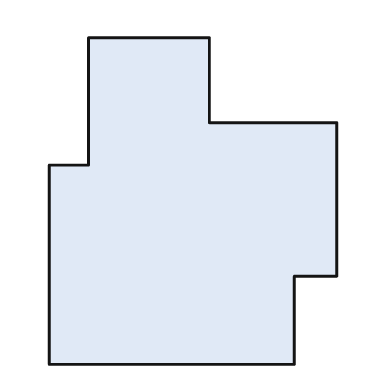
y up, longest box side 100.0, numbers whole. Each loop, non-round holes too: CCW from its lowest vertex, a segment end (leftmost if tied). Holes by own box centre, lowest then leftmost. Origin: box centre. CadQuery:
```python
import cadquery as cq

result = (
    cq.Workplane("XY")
    .moveTo(-44.0, -50.0)
    .lineTo(31.0, -50.0)
    .lineTo(31.0, -23.0)
    .lineTo(44.0, -23.0)
    .lineTo(44.0, 24.0)
    .lineTo(5.0, 24.0)
    .lineTo(5.0, 50.0)
    .lineTo(-32.0, 50.0)
    .lineTo(-32.0, 11.0)
    .lineTo(-44.0, 11.0)
    .close()
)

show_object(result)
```